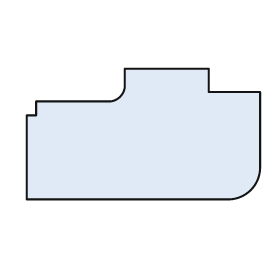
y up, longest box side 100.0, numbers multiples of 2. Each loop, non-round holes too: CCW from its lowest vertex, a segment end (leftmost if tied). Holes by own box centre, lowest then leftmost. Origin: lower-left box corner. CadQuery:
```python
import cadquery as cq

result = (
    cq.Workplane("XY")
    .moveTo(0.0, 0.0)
    .lineTo(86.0, 0.0)
    .threePointArc((96.0, 4.0), (100.0, 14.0))
    .lineTo(100.0, 46.0)
    .lineTo(78.0, 46.0)
    .lineTo(78.0, 56.0)
    .lineTo(42.0, 56.0)
    .lineTo(42.0, 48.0)
    .threePointArc((40.0, 44.0), (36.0, 42.0))
    .lineTo(4.0, 42.0)
    .lineTo(4.0, 36.0)
    .lineTo(0.0, 36.0)
    .close()
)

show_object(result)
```